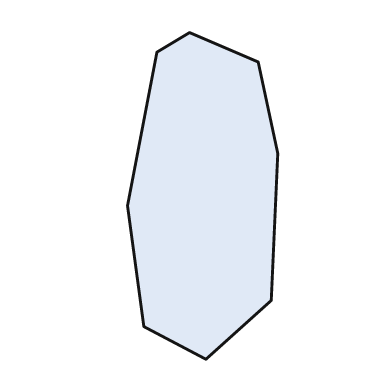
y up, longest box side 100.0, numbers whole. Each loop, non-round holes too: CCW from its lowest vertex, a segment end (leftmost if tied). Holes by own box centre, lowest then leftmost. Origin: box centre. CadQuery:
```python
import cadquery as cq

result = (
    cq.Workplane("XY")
    .moveTo(1.0, -50.0)
    .lineTo(21.0, -32.0)
    .lineTo(23.0, 13.0)
    .lineTo(17.0, 41.0)
    .lineTo(-4.0, 50.0)
    .lineTo(-14.0, 44.0)
    .lineTo(-23.0, -3.0)
    .lineTo(-18.0, -40.0)
    .close()
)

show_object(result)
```